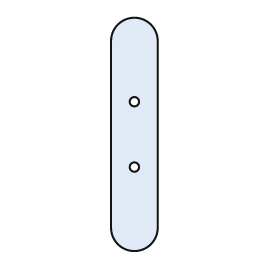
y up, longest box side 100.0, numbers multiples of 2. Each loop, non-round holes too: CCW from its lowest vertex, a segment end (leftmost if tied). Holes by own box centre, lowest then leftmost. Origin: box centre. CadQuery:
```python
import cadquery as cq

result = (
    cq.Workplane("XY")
    .moveTo(-10.0, -40.0)
    .threePointArc((0.0, -50.0), (10.0, -40.0))
    .lineTo(10.0, 40.0)
    .threePointArc((0.0, 50.0), (-10.0, 40.0))
    .close()
    .moveTo(0.0, -14.0)
    .circle(2.0)
    .moveTo(0.0, 14.0)
    .circle(2.0)
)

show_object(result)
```